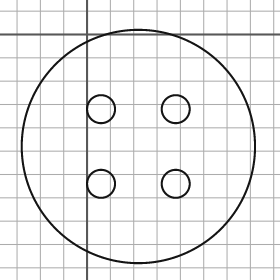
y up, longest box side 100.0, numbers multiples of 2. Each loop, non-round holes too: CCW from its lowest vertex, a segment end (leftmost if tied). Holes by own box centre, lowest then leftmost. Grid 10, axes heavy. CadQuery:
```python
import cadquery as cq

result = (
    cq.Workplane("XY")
    .moveTo(22.0, -48.0)
    .circle(50.0)
    .moveTo(6.0, -64.0)
    .circle(6.0)
    .moveTo(38.0, -64.0)
    .circle(6.0)
    .moveTo(6.0, -32.0)
    .circle(6.0)
    .moveTo(38.0, -32.0)
    .circle(6.0)
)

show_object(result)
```